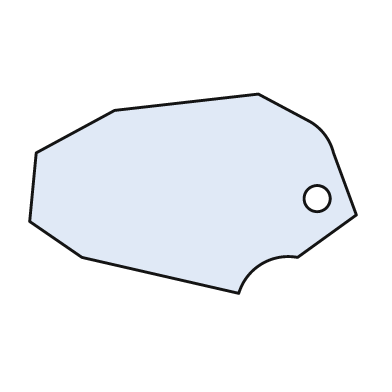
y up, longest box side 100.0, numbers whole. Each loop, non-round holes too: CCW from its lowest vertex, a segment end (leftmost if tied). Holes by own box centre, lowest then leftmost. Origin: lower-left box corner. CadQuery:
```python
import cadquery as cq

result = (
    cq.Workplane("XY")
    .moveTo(64.0, 0.0)
    .threePointArc((71.0, 9.0), (82.0, 11.0))
    .lineTo(100.0, 24.0)
    .lineTo(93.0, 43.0)
    .threePointArc((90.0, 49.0), (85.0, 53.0))
    .lineTo(70.0, 61.0)
    .lineTo(26.0, 56.0)
    .lineTo(2.0, 43.0)
    .lineTo(0.0, 22.0)
    .lineTo(16.0, 11.0)
    .close()
    .moveTo(88.0, 29.0)
    .circle(4.0)
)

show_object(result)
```